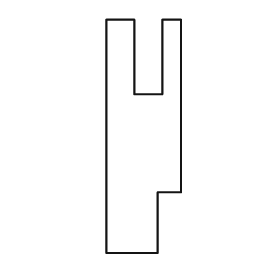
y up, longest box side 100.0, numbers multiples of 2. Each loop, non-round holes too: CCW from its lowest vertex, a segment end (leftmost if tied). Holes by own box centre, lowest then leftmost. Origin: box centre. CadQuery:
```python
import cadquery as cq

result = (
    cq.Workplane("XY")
    .moveTo(-16.0, -50.0)
    .lineTo(6.0, -50.0)
    .lineTo(6.0, -24.0)
    .lineTo(16.0, -24.0)
    .lineTo(16.0, 50.0)
    .lineTo(8.0, 50.0)
    .lineTo(8.0, 18.0)
    .lineTo(-4.0, 18.0)
    .lineTo(-4.0, 50.0)
    .lineTo(-16.0, 50.0)
    .close()
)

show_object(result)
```